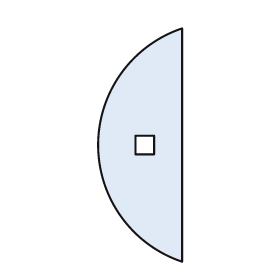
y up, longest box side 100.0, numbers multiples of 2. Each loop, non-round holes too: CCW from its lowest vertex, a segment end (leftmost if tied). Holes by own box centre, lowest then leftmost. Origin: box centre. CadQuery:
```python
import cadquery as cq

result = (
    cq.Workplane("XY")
    .moveTo(18.0, -50.0)
    .lineTo(18.0, 50.0)
    .threePointArc((-18.0, 0.0), (18.0, -50.0))
    .close()
    .moveTo(-2.0, -4.0)
    .lineTo(6.0, -4.0)
    .lineTo(6.0, 4.0)
    .lineTo(-2.0, 4.0)
    .close()
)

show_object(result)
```